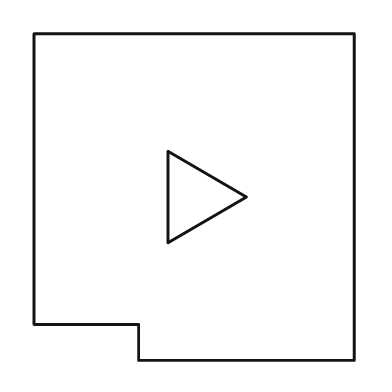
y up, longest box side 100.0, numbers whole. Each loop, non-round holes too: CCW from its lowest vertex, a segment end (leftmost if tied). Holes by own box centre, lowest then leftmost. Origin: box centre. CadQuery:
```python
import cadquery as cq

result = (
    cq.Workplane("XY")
    .moveTo(-17.0, -50.0)
    .lineTo(49.0, -50.0)
    .lineTo(49.0, 50.0)
    .lineTo(-49.0, 50.0)
    .lineTo(-49.0, -39.0)
    .lineTo(-17.0, -39.0)
    .close()
    .moveTo(-8.0, -14.0)
    .lineTo(16.0, 0.0)
    .lineTo(-8.0, 14.0)
    .close()
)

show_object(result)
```